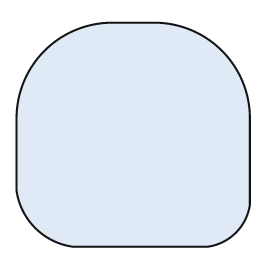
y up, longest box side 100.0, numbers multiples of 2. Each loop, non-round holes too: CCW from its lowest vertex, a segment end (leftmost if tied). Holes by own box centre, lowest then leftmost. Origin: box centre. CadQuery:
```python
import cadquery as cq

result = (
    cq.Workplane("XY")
    .moveTo(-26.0, -48.0)
    .lineTo(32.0, -48.0)
    .threePointArc((44.0, -42.0), (50.0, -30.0))
    .lineTo(50.0, 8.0)
    .threePointArc((38.0, 36.0), (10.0, 48.0))
    .lineTo(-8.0, 48.0)
    .threePointArc((-38.0, 36.0), (-50.0, 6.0))
    .lineTo(-50.0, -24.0)
    .threePointArc((-42.0, -40.0), (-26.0, -48.0))
    .close()
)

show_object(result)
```